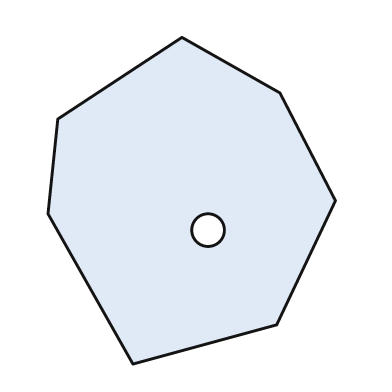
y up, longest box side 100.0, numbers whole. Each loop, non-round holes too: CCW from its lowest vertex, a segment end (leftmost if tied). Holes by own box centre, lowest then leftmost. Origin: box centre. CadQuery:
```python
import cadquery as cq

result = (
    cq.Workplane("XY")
    .moveTo(-18.0, -50.0)
    .lineTo(26.0, -38.0)
    .lineTo(44.0, 0.0)
    .lineTo(27.0, 33.0)
    .lineTo(-3.0, 50.0)
    .lineTo(-41.0, 25.0)
    .lineTo(-44.0, -4.0)
    .close()
    .moveTo(5.0, -9.0)
    .circle(5.0)
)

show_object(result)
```